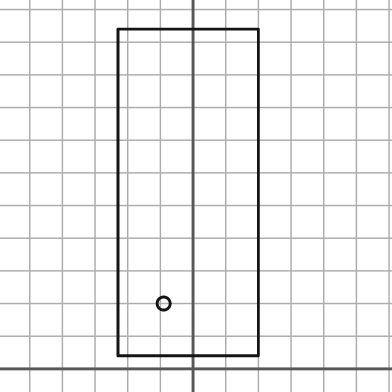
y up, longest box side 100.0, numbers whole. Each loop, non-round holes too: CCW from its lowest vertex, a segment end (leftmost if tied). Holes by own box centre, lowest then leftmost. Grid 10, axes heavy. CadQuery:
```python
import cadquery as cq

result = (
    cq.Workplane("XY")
    .moveTo(-23.0, 4.0)
    .lineTo(20.0, 4.0)
    .lineTo(20.0, 104.0)
    .lineTo(-23.0, 104.0)
    .close()
    .moveTo(-9.0, 20.0)
    .circle(2.0)
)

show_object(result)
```